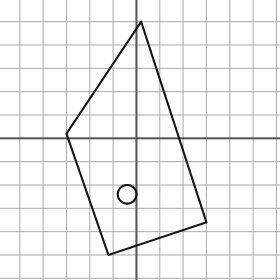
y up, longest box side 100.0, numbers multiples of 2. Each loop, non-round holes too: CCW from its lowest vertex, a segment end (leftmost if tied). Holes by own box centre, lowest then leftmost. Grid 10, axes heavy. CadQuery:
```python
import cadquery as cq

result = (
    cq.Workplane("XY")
    .moveTo(-12.0, -50.0)
    .lineTo(30.0, -36.0)
    .lineTo(2.0, 50.0)
    .lineTo(-30.0, 2.0)
    .close()
    .moveTo(-4.0, -24.0)
    .circle(4.0)
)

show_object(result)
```